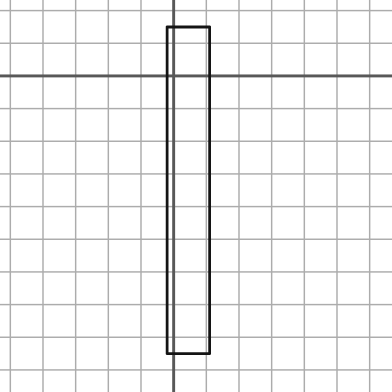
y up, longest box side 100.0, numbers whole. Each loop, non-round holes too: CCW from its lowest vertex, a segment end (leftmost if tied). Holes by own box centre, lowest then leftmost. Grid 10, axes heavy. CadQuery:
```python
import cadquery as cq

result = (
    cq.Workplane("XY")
    .moveTo(-2.0, -85.0)
    .lineTo(11.0, -85.0)
    .lineTo(11.0, 15.0)
    .lineTo(-2.0, 15.0)
    .close()
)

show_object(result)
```